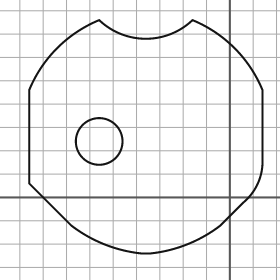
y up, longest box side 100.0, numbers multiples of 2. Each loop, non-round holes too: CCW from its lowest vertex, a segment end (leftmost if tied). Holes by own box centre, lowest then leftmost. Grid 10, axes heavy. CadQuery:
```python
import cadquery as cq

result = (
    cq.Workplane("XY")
    .moveTo(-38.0, -24.0)
    .lineTo(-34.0, -24.0)
    .threePointArc((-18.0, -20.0), (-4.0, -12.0))
    .lineTo(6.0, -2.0)
    .threePointArc((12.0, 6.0), (14.0, 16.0))
    .lineTo(14.0, 46.0)
    .threePointArc((2.0, 64.0), (-16.0, 76.0))
    .threePointArc((-36.0, 68.0), (-56.0, 76.0))
    .threePointArc((-74.0, 64.0), (-86.0, 46.0))
    .lineTo(-86.0, 6.0)
    .lineTo(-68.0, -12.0)
    .threePointArc((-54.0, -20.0), (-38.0, -24.0))
    .close()
    .moveTo(-56.0, 24.0)
    .circle(10.0)
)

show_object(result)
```